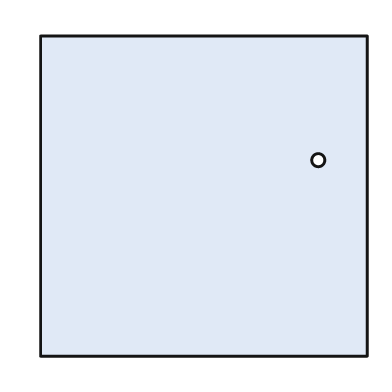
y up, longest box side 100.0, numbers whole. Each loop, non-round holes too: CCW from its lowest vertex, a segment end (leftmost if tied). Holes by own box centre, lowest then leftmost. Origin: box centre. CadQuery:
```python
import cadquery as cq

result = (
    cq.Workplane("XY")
    .moveTo(-50.0, -49.0)
    .lineTo(50.0, -49.0)
    .lineTo(50.0, 49.0)
    .lineTo(-50.0, 49.0)
    .close()
    .moveTo(35.0, 11.0)
    .circle(2.0)
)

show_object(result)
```